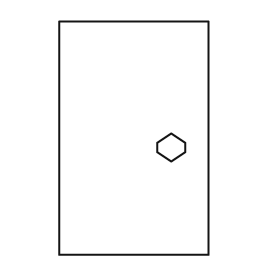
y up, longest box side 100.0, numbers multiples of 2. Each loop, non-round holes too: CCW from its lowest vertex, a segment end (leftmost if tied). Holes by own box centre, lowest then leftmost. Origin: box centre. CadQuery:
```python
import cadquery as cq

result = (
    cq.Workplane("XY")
    .moveTo(-32.0, -50.0)
    .lineTo(32.0, -50.0)
    .lineTo(32.0, 50.0)
    .lineTo(-32.0, 50.0)
    .close()
    .moveTo(16.0, -10.0)
    .lineTo(22.0, -6.0)
    .lineTo(22.0, -2.0)
    .lineTo(16.0, 2.0)
    .lineTo(10.0, -2.0)
    .lineTo(10.0, -6.0)
    .close()
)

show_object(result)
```